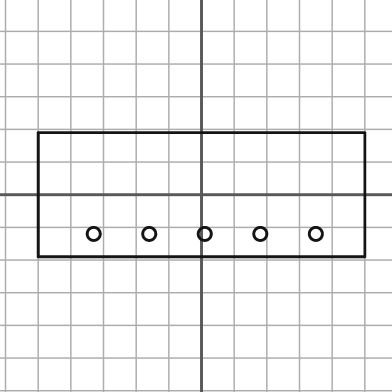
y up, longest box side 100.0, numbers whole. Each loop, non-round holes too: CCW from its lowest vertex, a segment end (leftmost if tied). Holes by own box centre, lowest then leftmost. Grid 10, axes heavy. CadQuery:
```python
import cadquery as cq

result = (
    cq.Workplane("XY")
    .moveTo(-50.0, -19.0)
    .lineTo(50.0, -19.0)
    .lineTo(50.0, 19.0)
    .lineTo(-50.0, 19.0)
    .close()
    .moveTo(-33.0, -12.0)
    .circle(2.0)
    .moveTo(-16.0, -12.0)
    .circle(2.0)
    .moveTo(1.0, -12.0)
    .circle(2.0)
    .moveTo(18.0, -12.0)
    .circle(2.0)
    .moveTo(35.0, -12.0)
    .circle(2.0)
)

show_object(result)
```